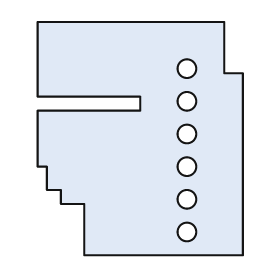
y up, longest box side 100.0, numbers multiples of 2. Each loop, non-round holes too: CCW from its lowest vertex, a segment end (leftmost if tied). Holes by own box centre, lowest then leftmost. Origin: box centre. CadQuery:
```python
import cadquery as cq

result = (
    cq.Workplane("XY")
    .moveTo(-24.0, -50.0)
    .lineTo(44.0, -50.0)
    .lineTo(44.0, 28.0)
    .lineTo(36.0, 28.0)
    .lineTo(36.0, 50.0)
    .lineTo(-44.0, 50.0)
    .lineTo(-44.0, 18.0)
    .lineTo(0.0, 18.0)
    .lineTo(0.0, 12.0)
    .lineTo(-44.0, 12.0)
    .lineTo(-44.0, -12.0)
    .lineTo(-40.0, -12.0)
    .lineTo(-40.0, -22.0)
    .lineTo(-34.0, -22.0)
    .lineTo(-34.0, -28.0)
    .lineTo(-24.0, -28.0)
    .close()
    .moveTo(20.0, -40.0)
    .circle(4.0)
    .moveTo(20.0, -26.0)
    .circle(4.0)
    .moveTo(20.0, -12.0)
    .circle(4.0)
    .moveTo(20.0, 2.0)
    .circle(4.0)
    .moveTo(20.0, 16.0)
    .circle(4.0)
    .moveTo(20.0, 30.0)
    .circle(4.0)
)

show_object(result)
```